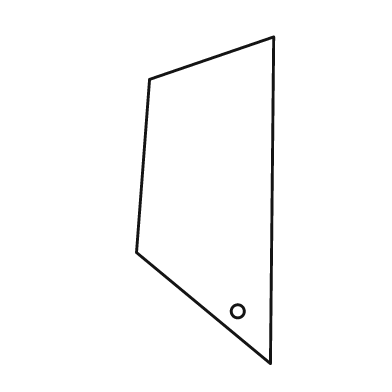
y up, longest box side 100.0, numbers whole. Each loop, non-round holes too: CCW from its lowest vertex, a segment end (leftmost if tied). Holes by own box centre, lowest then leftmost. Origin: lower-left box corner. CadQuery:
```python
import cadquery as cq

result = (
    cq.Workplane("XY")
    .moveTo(41.0, 0.0)
    .lineTo(42.0, 100.0)
    .lineTo(4.0, 87.0)
    .lineTo(0.0, 34.0)
    .close()
    .moveTo(31.0, 16.0)
    .circle(2.0)
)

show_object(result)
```